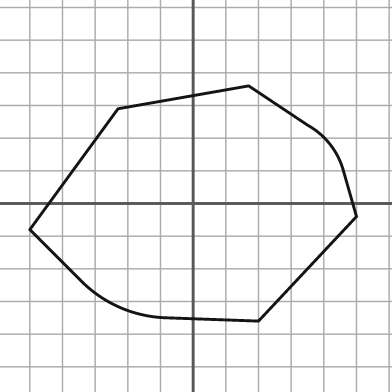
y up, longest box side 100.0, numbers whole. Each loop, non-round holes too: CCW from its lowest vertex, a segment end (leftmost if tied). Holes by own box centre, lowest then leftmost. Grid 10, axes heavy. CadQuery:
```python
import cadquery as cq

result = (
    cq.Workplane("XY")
    .moveTo(20.0, -36.0)
    .lineTo(50.0, -4.0)
    .lineTo(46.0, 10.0)
    .threePointArc((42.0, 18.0), (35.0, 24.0))
    .lineTo(17.0, 36.0)
    .lineTo(-23.0, 29.0)
    .lineTo(-50.0, -8.0)
    .lineTo(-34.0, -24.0)
    .threePointArc((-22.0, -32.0), (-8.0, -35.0))
    .close()
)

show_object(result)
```